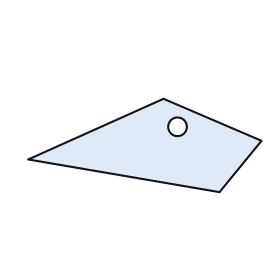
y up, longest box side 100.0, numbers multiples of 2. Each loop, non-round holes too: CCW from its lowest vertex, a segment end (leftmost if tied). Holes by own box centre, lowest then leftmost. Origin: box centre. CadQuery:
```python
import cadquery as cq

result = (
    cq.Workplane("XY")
    .moveTo(32.0, -20.0)
    .lineTo(50.0, 2.0)
    .lineTo(8.0, 20.0)
    .lineTo(-50.0, -6.0)
    .close()
    .moveTo(14.0, 8.0)
    .circle(4.0)
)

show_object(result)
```